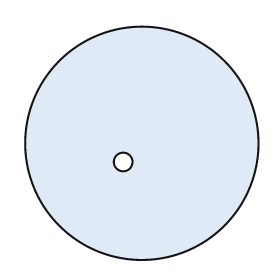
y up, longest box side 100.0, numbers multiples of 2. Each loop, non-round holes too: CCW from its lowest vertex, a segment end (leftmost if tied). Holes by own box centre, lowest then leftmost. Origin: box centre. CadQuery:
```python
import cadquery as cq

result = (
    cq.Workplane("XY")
    .moveTo(0.0, 0.0)
    .circle(50.0)
    .moveTo(-8.0, -8.0)
    .circle(4.0)
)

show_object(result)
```